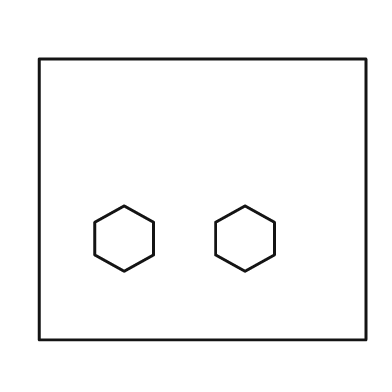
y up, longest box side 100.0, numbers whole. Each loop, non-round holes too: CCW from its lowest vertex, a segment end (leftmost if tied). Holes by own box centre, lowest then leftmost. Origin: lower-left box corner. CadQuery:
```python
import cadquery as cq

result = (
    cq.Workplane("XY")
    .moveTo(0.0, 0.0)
    .lineTo(100.0, 0.0)
    .lineTo(100.0, 86.0)
    .lineTo(0.0, 86.0)
    .close()
    .moveTo(26.0, 21.0)
    .lineTo(35.0, 26.0)
    .lineTo(35.0, 36.0)
    .lineTo(26.0, 41.0)
    .lineTo(17.0, 36.0)
    .lineTo(17.0, 26.0)
    .close()
    .moveTo(63.0, 21.0)
    .lineTo(72.0, 26.0)
    .lineTo(72.0, 36.0)
    .lineTo(63.0, 41.0)
    .lineTo(54.0, 36.0)
    .lineTo(54.0, 26.0)
    .close()
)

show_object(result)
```